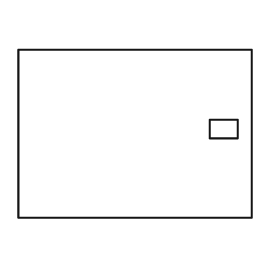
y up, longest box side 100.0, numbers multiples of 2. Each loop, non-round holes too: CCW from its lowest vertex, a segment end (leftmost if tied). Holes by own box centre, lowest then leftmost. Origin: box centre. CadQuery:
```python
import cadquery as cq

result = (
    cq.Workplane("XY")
    .moveTo(-50.0, -36.0)
    .lineTo(50.0, -36.0)
    .lineTo(50.0, 36.0)
    .lineTo(-50.0, 36.0)
    .close()
    .moveTo(32.0, -2.0)
    .lineTo(44.0, -2.0)
    .lineTo(44.0, 6.0)
    .lineTo(32.0, 6.0)
    .close()
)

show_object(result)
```